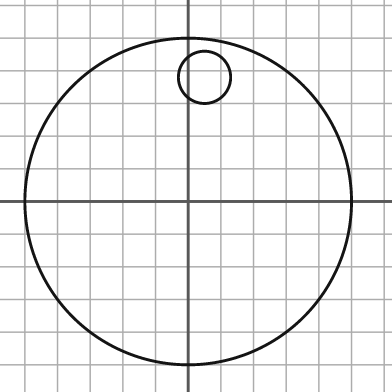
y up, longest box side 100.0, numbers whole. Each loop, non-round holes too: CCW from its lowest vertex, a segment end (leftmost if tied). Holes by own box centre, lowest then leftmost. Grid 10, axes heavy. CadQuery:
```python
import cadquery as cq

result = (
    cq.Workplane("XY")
    .moveTo(0.0, 0.0)
    .circle(50.0)
    .moveTo(5.0, 38.0)
    .circle(8.0)
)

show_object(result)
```